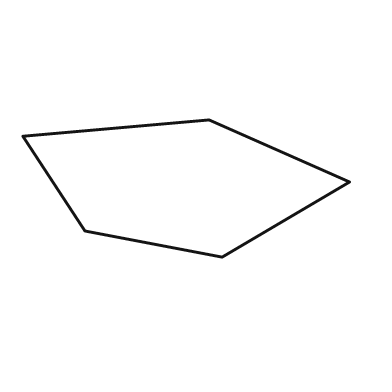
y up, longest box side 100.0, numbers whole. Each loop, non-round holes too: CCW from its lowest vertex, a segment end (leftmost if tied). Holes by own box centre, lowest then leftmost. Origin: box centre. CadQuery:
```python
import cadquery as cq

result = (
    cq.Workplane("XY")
    .moveTo(11.0, -21.0)
    .lineTo(50.0, 2.0)
    .lineTo(7.0, 21.0)
    .lineTo(-50.0, 16.0)
    .lineTo(-31.0, -13.0)
    .close()
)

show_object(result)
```